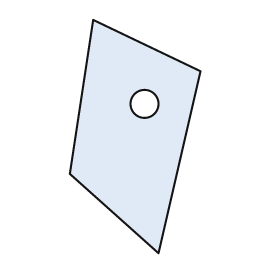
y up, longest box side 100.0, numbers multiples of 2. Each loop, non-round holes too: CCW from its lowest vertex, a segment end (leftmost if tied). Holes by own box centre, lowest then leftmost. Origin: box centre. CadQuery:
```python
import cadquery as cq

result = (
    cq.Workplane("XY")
    .moveTo(10.0, -50.0)
    .lineTo(28.0, 28.0)
    .lineTo(-18.0, 50.0)
    .lineTo(-28.0, -16.0)
    .close()
    .moveTo(4.0, 14.0)
    .circle(6.0)
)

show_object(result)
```